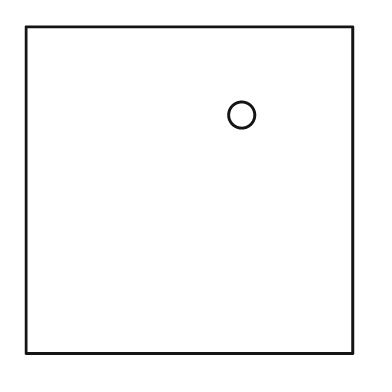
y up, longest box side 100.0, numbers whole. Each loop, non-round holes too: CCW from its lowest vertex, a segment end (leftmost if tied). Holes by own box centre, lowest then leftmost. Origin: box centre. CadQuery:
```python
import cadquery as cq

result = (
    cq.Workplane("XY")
    .moveTo(-50.0, -50.0)
    .lineTo(50.0, -50.0)
    .lineTo(50.0, 50.0)
    .lineTo(-50.0, 50.0)
    .close()
    .moveTo(16.0, 23.0)
    .circle(4.0)
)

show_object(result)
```